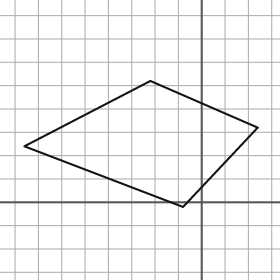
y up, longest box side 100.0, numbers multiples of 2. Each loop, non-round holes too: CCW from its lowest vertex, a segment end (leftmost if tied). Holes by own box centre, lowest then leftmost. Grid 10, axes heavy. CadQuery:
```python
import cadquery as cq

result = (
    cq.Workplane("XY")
    .moveTo(-8.0, -2.0)
    .lineTo(24.0, 32.0)
    .lineTo(-22.0, 52.0)
    .lineTo(-76.0, 24.0)
    .close()
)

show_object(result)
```